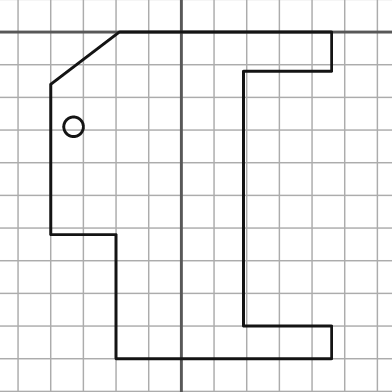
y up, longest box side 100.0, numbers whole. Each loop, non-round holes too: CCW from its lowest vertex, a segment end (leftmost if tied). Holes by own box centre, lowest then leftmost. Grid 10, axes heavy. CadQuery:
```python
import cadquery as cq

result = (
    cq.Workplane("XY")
    .moveTo(-20.0, -100.0)
    .lineTo(46.0, -100.0)
    .lineTo(46.0, -90.0)
    .lineTo(19.0, -90.0)
    .lineTo(19.0, -12.0)
    .lineTo(46.0, -12.0)
    .lineTo(46.0, 0.0)
    .lineTo(-19.0, 0.0)
    .lineTo(-40.0, -16.0)
    .lineTo(-40.0, -62.0)
    .lineTo(-20.0, -62.0)
    .close()
    .moveTo(-33.0, -29.0)
    .circle(3.0)
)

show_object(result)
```